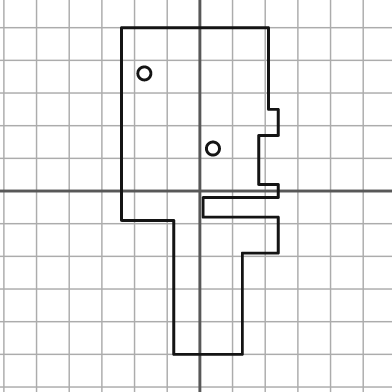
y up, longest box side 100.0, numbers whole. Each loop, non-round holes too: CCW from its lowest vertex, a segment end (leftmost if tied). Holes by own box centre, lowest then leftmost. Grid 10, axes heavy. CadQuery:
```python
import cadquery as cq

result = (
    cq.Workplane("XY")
    .moveTo(-8.0, -50.0)
    .lineTo(13.0, -50.0)
    .lineTo(13.0, -19.0)
    .lineTo(24.0, -19.0)
    .lineTo(24.0, -8.0)
    .lineTo(1.0, -8.0)
    .lineTo(1.0, -2.0)
    .lineTo(24.0, -2.0)
    .lineTo(24.0, 2.0)
    .lineTo(18.0, 2.0)
    .lineTo(18.0, 17.0)
    .lineTo(24.0, 17.0)
    .lineTo(24.0, 25.0)
    .lineTo(21.0, 25.0)
    .lineTo(21.0, 50.0)
    .lineTo(-24.0, 50.0)
    .lineTo(-24.0, -9.0)
    .lineTo(-8.0, -9.0)
    .close()
    .moveTo(4.0, 13.0)
    .circle(2.0)
    .moveTo(-17.0, 36.0)
    .circle(2.0)
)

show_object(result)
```